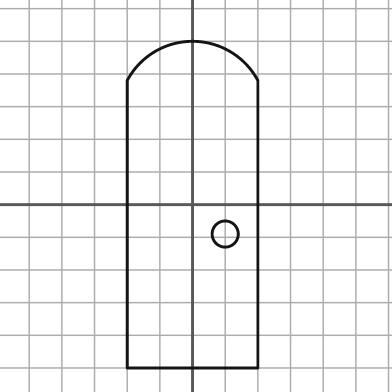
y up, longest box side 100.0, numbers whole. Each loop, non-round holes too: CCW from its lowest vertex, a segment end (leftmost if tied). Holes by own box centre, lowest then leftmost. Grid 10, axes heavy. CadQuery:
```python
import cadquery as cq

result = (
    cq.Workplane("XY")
    .moveTo(-20.0, -50.0)
    .lineTo(20.0, -50.0)
    .lineTo(20.0, 38.0)
    .threePointArc((0.0, 50.0), (-20.0, 38.0))
    .close()
    .moveTo(10.0, -9.0)
    .circle(4.0)
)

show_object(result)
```